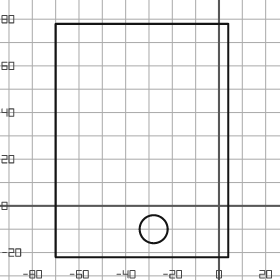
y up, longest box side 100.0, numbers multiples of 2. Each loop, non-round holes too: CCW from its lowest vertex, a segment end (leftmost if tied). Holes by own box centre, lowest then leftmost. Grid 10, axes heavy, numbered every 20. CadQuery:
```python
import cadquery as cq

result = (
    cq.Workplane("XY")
    .moveTo(-70.0, -22.0)
    .lineTo(4.0, -22.0)
    .lineTo(4.0, 78.0)
    .lineTo(-70.0, 78.0)
    .close()
    .moveTo(-28.0, -10.0)
    .circle(6.0)
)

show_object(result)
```